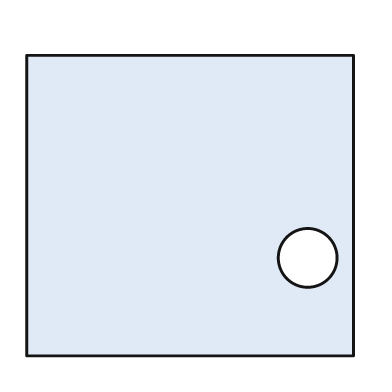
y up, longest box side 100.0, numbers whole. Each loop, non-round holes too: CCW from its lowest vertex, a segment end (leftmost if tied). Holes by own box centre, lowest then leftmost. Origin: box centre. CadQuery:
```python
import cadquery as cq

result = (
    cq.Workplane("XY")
    .moveTo(-50.0, -46.0)
    .lineTo(50.0, -46.0)
    .lineTo(50.0, 46.0)
    .lineTo(-50.0, 46.0)
    .close()
    .moveTo(36.0, -16.0)
    .circle(9.0)
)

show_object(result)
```